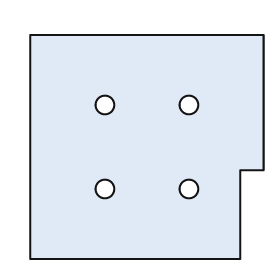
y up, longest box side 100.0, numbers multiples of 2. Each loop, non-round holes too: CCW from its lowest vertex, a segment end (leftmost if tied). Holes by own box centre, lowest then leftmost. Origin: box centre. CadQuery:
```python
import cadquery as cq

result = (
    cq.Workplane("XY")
    .moveTo(-50.0, -48.0)
    .lineTo(40.0, -48.0)
    .lineTo(40.0, -10.0)
    .lineTo(50.0, -10.0)
    .lineTo(50.0, 48.0)
    .lineTo(-50.0, 48.0)
    .close()
    .moveTo(-18.0, -18.0)
    .circle(4.0)
    .moveTo(18.0, -18.0)
    .circle(4.0)
    .moveTo(-18.0, 18.0)
    .circle(4.0)
    .moveTo(18.0, 18.0)
    .circle(4.0)
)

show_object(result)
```